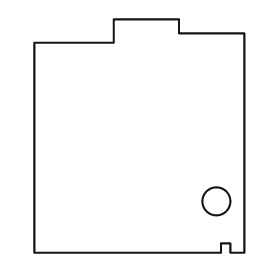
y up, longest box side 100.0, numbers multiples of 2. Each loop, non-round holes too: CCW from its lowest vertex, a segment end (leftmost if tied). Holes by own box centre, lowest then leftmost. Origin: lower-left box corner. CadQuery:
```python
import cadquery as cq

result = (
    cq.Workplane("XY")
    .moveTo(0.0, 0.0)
    .lineTo(80.0, 0.0)
    .lineTo(80.0, 4.0)
    .lineTo(84.0, 4.0)
    .lineTo(84.0, 0.0)
    .lineTo(90.0, 0.0)
    .lineTo(90.0, 94.0)
    .lineTo(62.0, 94.0)
    .lineTo(62.0, 100.0)
    .lineTo(34.0, 100.0)
    .lineTo(34.0, 90.0)
    .lineTo(0.0, 90.0)
    .close()
    .moveTo(78.0, 22.0)
    .circle(6.0)
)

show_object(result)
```